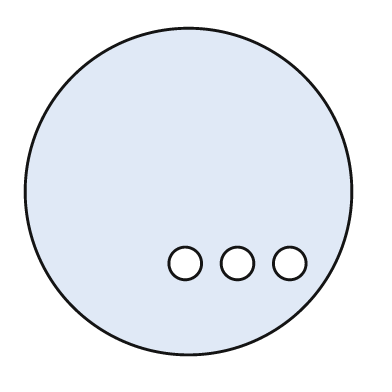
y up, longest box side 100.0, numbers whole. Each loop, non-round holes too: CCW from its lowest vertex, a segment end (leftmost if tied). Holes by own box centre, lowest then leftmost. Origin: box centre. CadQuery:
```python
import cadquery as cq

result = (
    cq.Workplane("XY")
    .moveTo(0.0, 0.0)
    .circle(50.0)
    .moveTo(-1.0, -22.0)
    .circle(5.0)
    .moveTo(15.0, -22.0)
    .circle(5.0)
    .moveTo(31.0, -22.0)
    .circle(5.0)
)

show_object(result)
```